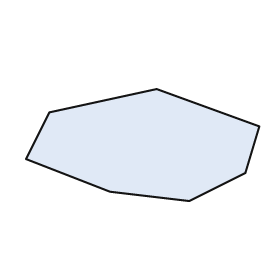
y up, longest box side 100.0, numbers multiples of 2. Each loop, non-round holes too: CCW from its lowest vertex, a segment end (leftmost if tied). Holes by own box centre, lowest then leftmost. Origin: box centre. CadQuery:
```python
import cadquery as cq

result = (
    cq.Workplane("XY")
    .moveTo(20.0, -24.0)
    .lineTo(44.0, -12.0)
    .lineTo(50.0, 8.0)
    .lineTo(6.0, 24.0)
    .lineTo(-40.0, 14.0)
    .lineTo(-50.0, -6.0)
    .lineTo(-14.0, -20.0)
    .close()
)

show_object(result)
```